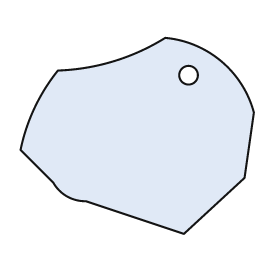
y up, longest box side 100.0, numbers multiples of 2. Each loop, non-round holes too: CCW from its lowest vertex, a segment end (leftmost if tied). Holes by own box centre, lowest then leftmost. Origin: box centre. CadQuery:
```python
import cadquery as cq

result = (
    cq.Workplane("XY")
    .moveTo(20.0, -42.0)
    .lineTo(46.0, -18.0)
    .lineTo(50.0, 10.0)
    .threePointArc((36.0, 32.0), (12.0, 42.0))
    .threePointArc((-10.0, 32.0), (-34.0, 28.0))
    .threePointArc((-44.0, 12.0), (-50.0, -6.0))
    .lineTo(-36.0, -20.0)
    .threePointArc((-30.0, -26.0), (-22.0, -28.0))
    .close()
    .moveTo(22.0, 26.0)
    .circle(4.0)
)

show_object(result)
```